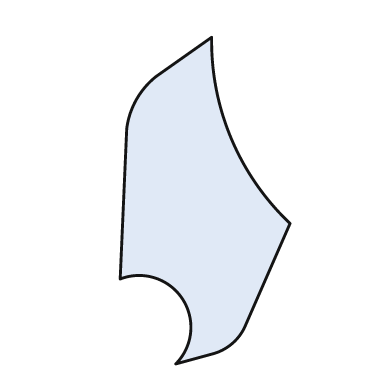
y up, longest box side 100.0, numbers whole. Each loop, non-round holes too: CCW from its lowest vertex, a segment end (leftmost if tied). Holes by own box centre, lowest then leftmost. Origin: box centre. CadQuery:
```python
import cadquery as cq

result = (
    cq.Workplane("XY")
    .moveTo(-9.0, -50.0)
    .lineTo(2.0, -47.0)
    .threePointArc((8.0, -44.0), (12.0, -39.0))
    .lineTo(26.0, -7.0)
    .threePointArc((8.0, 19.0), (2.0, 50.0))
    .lineTo(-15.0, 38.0)
    .threePointArc((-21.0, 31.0), (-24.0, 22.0))
    .lineTo(-26.0, -24.0)
    .threePointArc((-7.0, -30.0), (-9.0, -50.0))
    .close()
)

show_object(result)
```